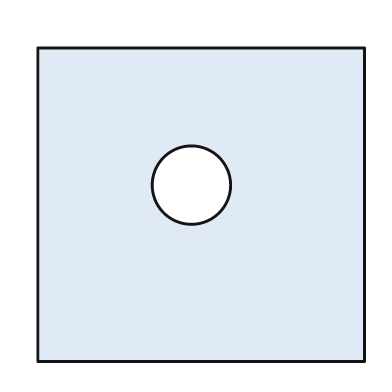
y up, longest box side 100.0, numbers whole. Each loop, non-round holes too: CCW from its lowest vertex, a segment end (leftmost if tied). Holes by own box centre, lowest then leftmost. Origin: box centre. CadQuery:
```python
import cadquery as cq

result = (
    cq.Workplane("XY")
    .moveTo(-50.0, -48.0)
    .lineTo(50.0, -48.0)
    .lineTo(50.0, 48.0)
    .lineTo(-50.0, 48.0)
    .close()
    .moveTo(-3.0, 6.0)
    .circle(12.0)
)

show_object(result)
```